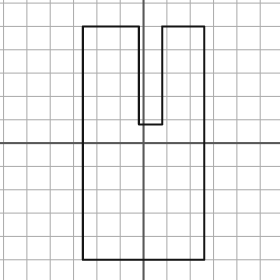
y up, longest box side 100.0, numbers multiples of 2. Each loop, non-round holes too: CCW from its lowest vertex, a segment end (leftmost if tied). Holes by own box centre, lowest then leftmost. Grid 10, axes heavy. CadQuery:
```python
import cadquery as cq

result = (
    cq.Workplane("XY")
    .moveTo(-26.0, -50.0)
    .lineTo(26.0, -50.0)
    .lineTo(26.0, 50.0)
    .lineTo(8.0, 50.0)
    .lineTo(8.0, 8.0)
    .lineTo(-2.0, 8.0)
    .lineTo(-2.0, 50.0)
    .lineTo(-26.0, 50.0)
    .close()
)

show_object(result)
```